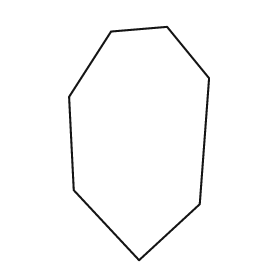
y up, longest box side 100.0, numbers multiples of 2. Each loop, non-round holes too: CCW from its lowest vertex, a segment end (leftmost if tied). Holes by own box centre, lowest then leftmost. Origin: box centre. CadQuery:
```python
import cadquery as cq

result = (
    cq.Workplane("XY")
    .moveTo(0.0, -50.0)
    .lineTo(26.0, -26.0)
    .lineTo(30.0, 28.0)
    .lineTo(12.0, 50.0)
    .lineTo(-12.0, 48.0)
    .lineTo(-30.0, 20.0)
    .lineTo(-28.0, -20.0)
    .close()
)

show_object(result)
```